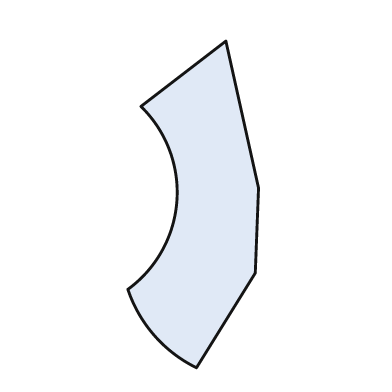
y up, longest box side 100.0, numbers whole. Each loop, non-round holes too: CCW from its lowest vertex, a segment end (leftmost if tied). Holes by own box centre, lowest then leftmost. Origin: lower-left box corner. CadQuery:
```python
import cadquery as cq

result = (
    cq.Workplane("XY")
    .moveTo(21.0, 0.0)
    .lineTo(39.0, 29.0)
    .lineTo(40.0, 55.0)
    .lineTo(30.0, 100.0)
    .lineTo(4.0, 80.0)
    .threePointArc((15.0, 51.0), (0.0, 24.0))
    .threePointArc((8.0, 10.0), (21.0, 0.0))
    .close()
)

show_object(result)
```